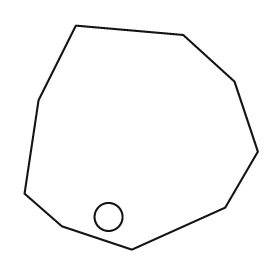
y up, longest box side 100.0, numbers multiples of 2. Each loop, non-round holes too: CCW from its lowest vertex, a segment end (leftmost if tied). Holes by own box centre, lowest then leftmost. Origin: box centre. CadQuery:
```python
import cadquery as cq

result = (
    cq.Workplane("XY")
    .moveTo(-4.0, -48.0)
    .lineTo(36.0, -30.0)
    .lineTo(50.0, -6.0)
    .lineTo(40.0, 24.0)
    .lineTo(18.0, 44.0)
    .lineTo(-28.0, 48.0)
    .lineTo(-44.0, 16.0)
    .lineTo(-50.0, -24.0)
    .lineTo(-34.0, -38.0)
    .close()
    .moveTo(-14.0, -34.0)
    .circle(6.0)
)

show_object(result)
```